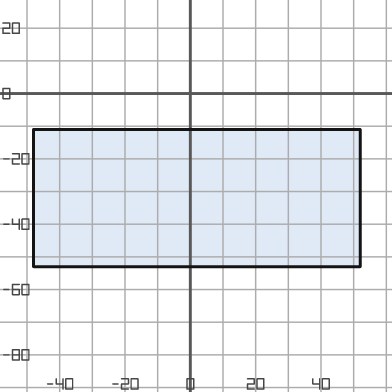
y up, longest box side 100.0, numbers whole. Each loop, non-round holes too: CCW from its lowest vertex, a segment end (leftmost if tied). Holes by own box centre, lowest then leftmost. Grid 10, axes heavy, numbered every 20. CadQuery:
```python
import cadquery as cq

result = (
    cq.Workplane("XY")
    .moveTo(-48.0, -53.0)
    .lineTo(52.0, -53.0)
    .lineTo(52.0, -11.0)
    .lineTo(-48.0, -11.0)
    .close()
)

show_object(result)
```